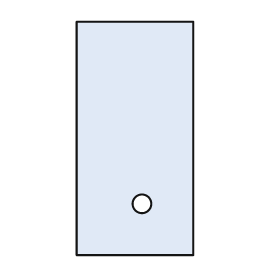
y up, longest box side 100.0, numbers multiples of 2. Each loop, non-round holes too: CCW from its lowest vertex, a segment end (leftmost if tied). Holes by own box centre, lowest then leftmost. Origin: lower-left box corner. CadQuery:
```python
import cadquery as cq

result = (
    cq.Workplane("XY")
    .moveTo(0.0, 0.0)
    .lineTo(50.0, 0.0)
    .lineTo(50.0, 100.0)
    .lineTo(0.0, 100.0)
    .close()
    .moveTo(28.0, 22.0)
    .circle(4.0)
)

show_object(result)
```